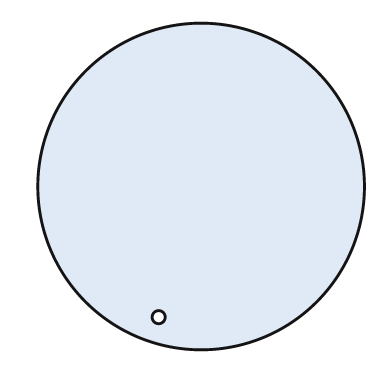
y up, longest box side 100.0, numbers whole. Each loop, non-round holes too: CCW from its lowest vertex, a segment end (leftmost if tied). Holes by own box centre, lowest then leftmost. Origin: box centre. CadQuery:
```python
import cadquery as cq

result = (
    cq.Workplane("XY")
    .moveTo(0.0, 0.0)
    .circle(50.0)
    .moveTo(-13.0, -40.0)
    .circle(2.0)
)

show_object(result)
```